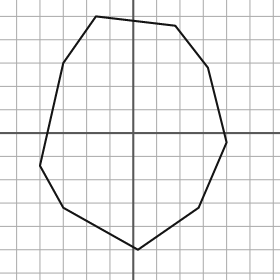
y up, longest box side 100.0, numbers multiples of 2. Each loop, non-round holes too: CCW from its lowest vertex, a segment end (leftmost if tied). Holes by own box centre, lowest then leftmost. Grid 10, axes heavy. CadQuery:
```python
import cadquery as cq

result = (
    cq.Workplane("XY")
    .moveTo(2.0, -50.0)
    .lineTo(28.0, -32.0)
    .lineTo(40.0, -4.0)
    .lineTo(32.0, 28.0)
    .lineTo(18.0, 46.0)
    .lineTo(-16.0, 50.0)
    .lineTo(-30.0, 30.0)
    .lineTo(-40.0, -14.0)
    .lineTo(-30.0, -32.0)
    .close()
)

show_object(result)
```